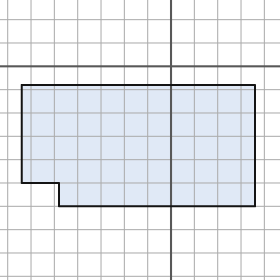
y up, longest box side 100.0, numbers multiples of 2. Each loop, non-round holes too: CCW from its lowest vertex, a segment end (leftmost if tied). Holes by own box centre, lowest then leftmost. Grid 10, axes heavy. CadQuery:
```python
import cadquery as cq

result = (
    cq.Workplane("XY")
    .moveTo(-48.0, -60.0)
    .lineTo(36.0, -60.0)
    .lineTo(36.0, -8.0)
    .lineTo(-64.0, -8.0)
    .lineTo(-64.0, -50.0)
    .lineTo(-48.0, -50.0)
    .close()
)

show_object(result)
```